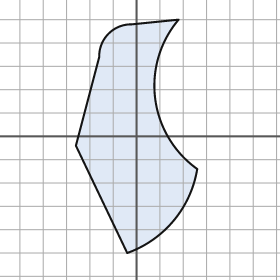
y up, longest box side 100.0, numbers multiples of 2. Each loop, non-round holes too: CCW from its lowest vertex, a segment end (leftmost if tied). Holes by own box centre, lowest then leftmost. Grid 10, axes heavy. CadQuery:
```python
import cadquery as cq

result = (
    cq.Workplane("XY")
    .moveTo(-4.0, -50.0)
    .threePointArc((16.0, -36.0), (26.0, -14.0))
    .threePointArc((8.0, 16.0), (18.0, 50.0))
    .lineTo(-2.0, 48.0)
    .threePointArc((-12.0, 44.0), (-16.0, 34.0))
    .lineTo(-26.0, -4.0)
    .close()
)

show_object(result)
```